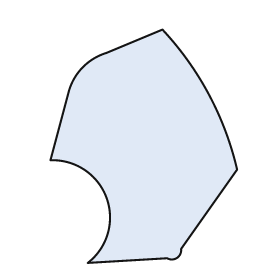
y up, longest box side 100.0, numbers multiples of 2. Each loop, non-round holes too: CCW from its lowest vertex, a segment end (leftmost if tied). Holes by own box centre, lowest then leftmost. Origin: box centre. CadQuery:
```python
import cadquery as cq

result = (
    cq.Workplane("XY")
    .moveTo(-24.0, -50.0)
    .lineTo(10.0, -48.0)
    .threePointArc((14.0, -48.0), (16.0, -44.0))
    .lineTo(40.0, -10.0)
    .threePointArc((28.0, 22.0), (8.0, 50.0))
    .lineTo(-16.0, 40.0)
    .threePointArc((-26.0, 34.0), (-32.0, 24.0))
    .lineTo(-40.0, -6.0)
    .threePointArc((-16.0, -22.0), (-24.0, -50.0))
    .close()
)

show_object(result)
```